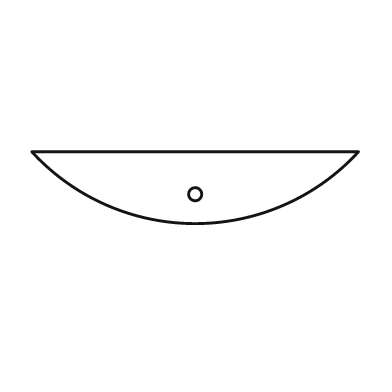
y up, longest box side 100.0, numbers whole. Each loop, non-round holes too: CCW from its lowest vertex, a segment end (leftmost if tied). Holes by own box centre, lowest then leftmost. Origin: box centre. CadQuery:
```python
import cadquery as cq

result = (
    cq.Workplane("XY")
    .moveTo(-50.0, 11.0)
    .threePointArc((0.0, -11.0), (50.0, 11.0))
    .close()
    .moveTo(0.0, -2.0)
    .circle(2.0)
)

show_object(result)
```